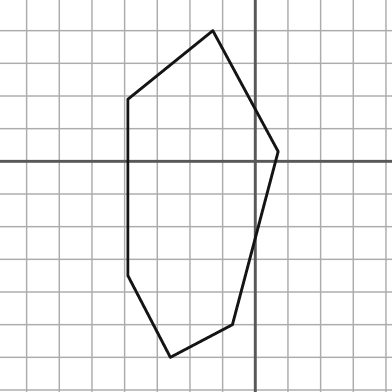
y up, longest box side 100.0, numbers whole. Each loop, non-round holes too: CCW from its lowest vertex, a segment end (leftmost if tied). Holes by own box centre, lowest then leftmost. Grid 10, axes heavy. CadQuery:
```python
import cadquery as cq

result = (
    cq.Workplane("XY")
    .moveTo(-26.0, -60.0)
    .lineTo(-7.0, -50.0)
    .lineTo(7.0, 3.0)
    .lineTo(-13.0, 40.0)
    .lineTo(-39.0, 19.0)
    .lineTo(-39.0, -35.0)
    .close()
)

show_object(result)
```